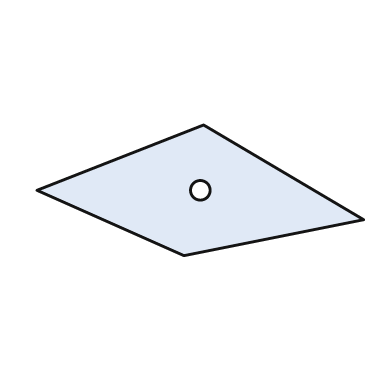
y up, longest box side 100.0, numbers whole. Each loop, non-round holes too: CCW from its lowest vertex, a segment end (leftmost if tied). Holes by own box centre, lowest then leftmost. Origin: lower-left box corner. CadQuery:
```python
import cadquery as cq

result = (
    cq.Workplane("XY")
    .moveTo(45.0, 0.0)
    .lineTo(100.0, 11.0)
    .lineTo(51.0, 40.0)
    .lineTo(0.0, 20.0)
    .close()
    .moveTo(50.0, 20.0)
    .circle(3.0)
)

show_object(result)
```